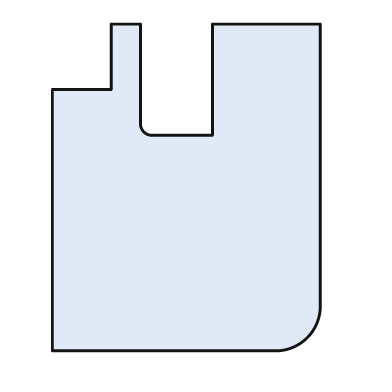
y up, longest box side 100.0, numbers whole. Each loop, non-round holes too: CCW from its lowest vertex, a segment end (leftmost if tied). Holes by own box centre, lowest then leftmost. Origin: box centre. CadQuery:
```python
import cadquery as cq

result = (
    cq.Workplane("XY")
    .moveTo(-41.0, -50.0)
    .lineTo(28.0, -50.0)
    .threePointArc((37.0, -46.0), (41.0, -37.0))
    .lineTo(41.0, 50.0)
    .lineTo(8.0, 50.0)
    .lineTo(8.0, 16.0)
    .lineTo(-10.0, 16.0)
    .threePointArc((-13.0, 17.0), (-14.0, 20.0))
    .lineTo(-14.0, 50.0)
    .lineTo(-23.0, 50.0)
    .lineTo(-23.0, 30.0)
    .lineTo(-41.0, 30.0)
    .close()
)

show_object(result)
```